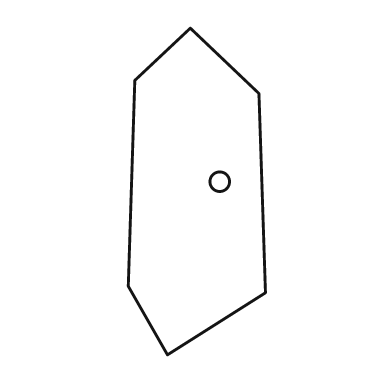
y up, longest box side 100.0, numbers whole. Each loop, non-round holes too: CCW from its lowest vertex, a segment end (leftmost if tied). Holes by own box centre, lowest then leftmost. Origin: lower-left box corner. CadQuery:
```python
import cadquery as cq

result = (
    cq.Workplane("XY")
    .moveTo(12.0, 0.0)
    .lineTo(42.0, 19.0)
    .lineTo(40.0, 80.0)
    .lineTo(19.0, 100.0)
    .lineTo(2.0, 84.0)
    .lineTo(0.0, 21.0)
    .close()
    .moveTo(28.0, 53.0)
    .circle(3.0)
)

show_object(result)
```